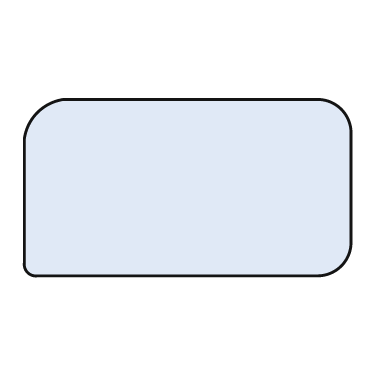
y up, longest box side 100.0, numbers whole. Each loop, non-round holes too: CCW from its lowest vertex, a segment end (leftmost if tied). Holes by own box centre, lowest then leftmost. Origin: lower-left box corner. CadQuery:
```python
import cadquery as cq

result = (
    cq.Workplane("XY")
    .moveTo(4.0, 0.0)
    .lineTo(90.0, 0.0)
    .threePointArc((97.0, 3.0), (100.0, 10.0))
    .lineTo(100.0, 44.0)
    .threePointArc((97.0, 51.0), (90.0, 54.0))
    .lineTo(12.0, 54.0)
    .threePointArc((4.0, 50.0), (0.0, 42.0))
    .lineTo(0.0, 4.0)
    .threePointArc((1.0, 1.0), (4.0, 0.0))
    .close()
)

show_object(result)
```